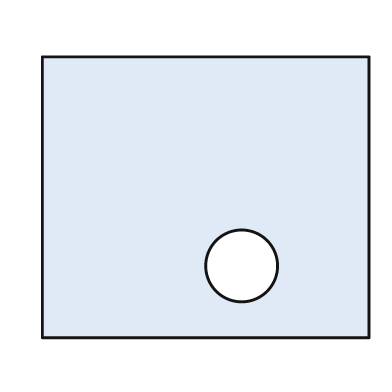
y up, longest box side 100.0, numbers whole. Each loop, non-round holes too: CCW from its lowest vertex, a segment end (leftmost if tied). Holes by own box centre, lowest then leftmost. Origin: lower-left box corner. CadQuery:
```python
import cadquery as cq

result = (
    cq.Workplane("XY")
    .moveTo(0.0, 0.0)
    .lineTo(100.0, 0.0)
    .lineTo(100.0, 86.0)
    .lineTo(0.0, 86.0)
    .close()
    .moveTo(61.0, 22.0)
    .circle(11.0)
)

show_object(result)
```